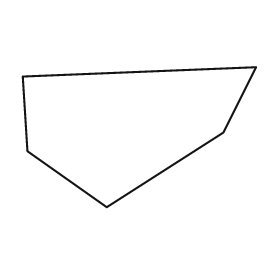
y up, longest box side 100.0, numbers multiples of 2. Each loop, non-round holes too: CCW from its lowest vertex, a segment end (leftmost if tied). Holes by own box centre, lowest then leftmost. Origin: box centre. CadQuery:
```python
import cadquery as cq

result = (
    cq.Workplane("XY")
    .moveTo(-14.0, -30.0)
    .lineTo(36.0, 2.0)
    .lineTo(50.0, 30.0)
    .lineTo(-50.0, 26.0)
    .lineTo(-48.0, -6.0)
    .close()
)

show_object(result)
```